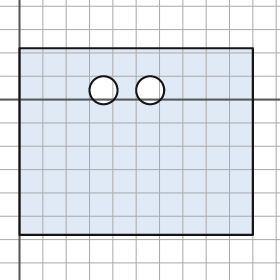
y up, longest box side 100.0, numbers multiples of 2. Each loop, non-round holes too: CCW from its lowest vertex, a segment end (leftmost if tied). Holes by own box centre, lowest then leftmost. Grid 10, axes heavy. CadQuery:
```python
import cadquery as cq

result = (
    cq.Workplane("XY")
    .moveTo(0.0, -58.0)
    .lineTo(100.0, -58.0)
    .lineTo(100.0, 22.0)
    .lineTo(0.0, 22.0)
    .close()
    .moveTo(36.0, 4.0)
    .circle(6.0)
    .moveTo(56.0, 4.0)
    .circle(6.0)
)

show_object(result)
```